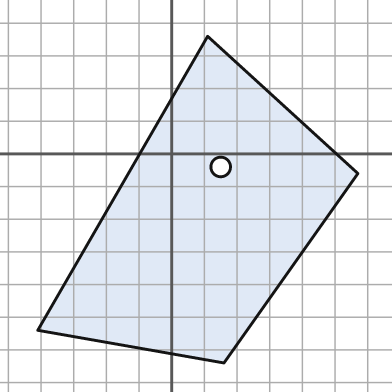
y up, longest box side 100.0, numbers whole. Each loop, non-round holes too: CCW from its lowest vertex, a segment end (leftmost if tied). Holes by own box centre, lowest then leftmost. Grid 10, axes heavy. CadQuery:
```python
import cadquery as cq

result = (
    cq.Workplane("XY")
    .moveTo(16.0, -64.0)
    .lineTo(57.0, -6.0)
    .lineTo(11.0, 36.0)
    .lineTo(-41.0, -54.0)
    .close()
    .moveTo(15.0, -4.0)
    .circle(3.0)
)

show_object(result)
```